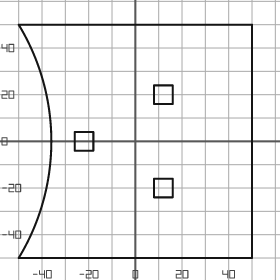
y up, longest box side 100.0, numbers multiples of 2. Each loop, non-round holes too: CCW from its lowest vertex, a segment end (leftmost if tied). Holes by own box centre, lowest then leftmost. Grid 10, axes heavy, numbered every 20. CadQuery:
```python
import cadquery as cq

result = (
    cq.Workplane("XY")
    .moveTo(-50.0, -50.0)
    .lineTo(50.0, -50.0)
    .lineTo(50.0, 50.0)
    .lineTo(-50.0, 50.0)
    .threePointArc((-36.0, 0.0), (-50.0, -50.0))
    .close()
    .moveTo(8.0, -24.0)
    .lineTo(16.0, -24.0)
    .lineTo(16.0, -16.0)
    .lineTo(8.0, -16.0)
    .close()
    .moveTo(-26.0, -4.0)
    .lineTo(-18.0, -4.0)
    .lineTo(-18.0, 4.0)
    .lineTo(-26.0, 4.0)
    .close()
    .moveTo(8.0, 16.0)
    .lineTo(16.0, 16.0)
    .lineTo(16.0, 24.0)
    .lineTo(8.0, 24.0)
    .close()
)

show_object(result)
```